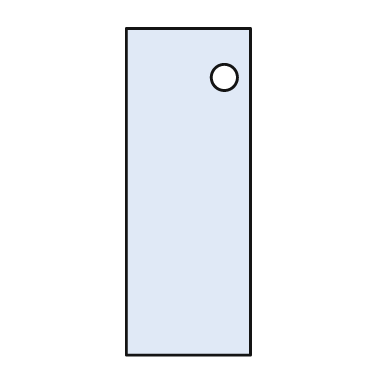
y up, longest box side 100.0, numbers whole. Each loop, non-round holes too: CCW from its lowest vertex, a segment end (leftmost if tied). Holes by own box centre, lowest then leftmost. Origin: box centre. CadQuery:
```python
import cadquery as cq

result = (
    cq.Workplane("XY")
    .moveTo(-19.0, -50.0)
    .lineTo(19.0, -50.0)
    .lineTo(19.0, 50.0)
    .lineTo(-19.0, 50.0)
    .close()
    .moveTo(11.0, 35.0)
    .circle(4.0)
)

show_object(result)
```